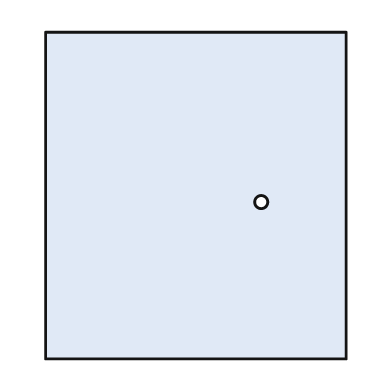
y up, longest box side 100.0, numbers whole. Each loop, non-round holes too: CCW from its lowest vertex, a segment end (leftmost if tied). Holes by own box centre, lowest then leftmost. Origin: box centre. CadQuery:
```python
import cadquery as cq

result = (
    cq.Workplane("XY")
    .moveTo(-46.0, -50.0)
    .lineTo(46.0, -50.0)
    .lineTo(46.0, 50.0)
    .lineTo(-46.0, 50.0)
    .close()
    .moveTo(20.0, -2.0)
    .circle(2.0)
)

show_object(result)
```